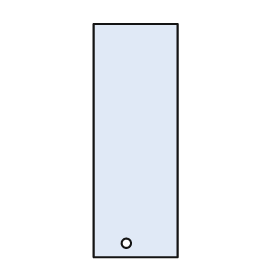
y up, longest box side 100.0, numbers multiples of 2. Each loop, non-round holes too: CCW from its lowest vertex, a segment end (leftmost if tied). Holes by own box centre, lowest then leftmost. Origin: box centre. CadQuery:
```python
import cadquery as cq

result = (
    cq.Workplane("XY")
    .moveTo(-18.0, -50.0)
    .lineTo(18.0, -50.0)
    .lineTo(18.0, 50.0)
    .lineTo(-18.0, 50.0)
    .close()
    .moveTo(-4.0, -44.0)
    .circle(2.0)
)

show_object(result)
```